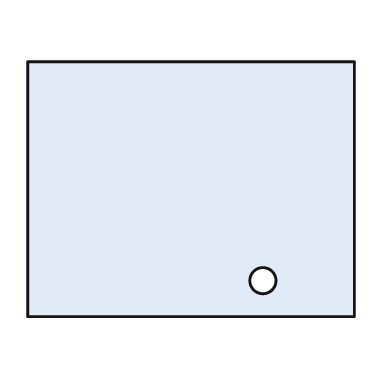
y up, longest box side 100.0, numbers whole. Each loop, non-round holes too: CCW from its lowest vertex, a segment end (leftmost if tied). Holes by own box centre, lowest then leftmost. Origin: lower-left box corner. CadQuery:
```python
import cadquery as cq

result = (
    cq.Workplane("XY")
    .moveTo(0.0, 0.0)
    .lineTo(100.0, 0.0)
    .lineTo(100.0, 78.0)
    .lineTo(0.0, 78.0)
    .close()
    .moveTo(72.0, 11.0)
    .circle(4.0)
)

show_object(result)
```